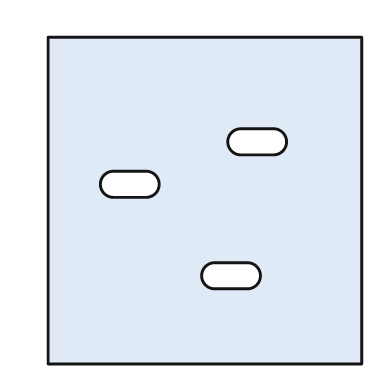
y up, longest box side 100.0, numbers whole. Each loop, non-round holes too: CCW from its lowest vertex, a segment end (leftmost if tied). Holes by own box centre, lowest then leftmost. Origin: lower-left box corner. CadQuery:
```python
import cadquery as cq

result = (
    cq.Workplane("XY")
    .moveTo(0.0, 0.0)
    .lineTo(96.0, 0.0)
    .lineTo(96.0, 100.0)
    .lineTo(0.0, 100.0)
    .close()
    .moveTo(51.0, 23.0)
    .lineTo(61.0, 23.0)
    .threePointArc((65.0, 27.0), (61.0, 31.0))
    .lineTo(51.0, 31.0)
    .threePointArc((47.0, 27.0), (51.0, 23.0))
    .close()
    .moveTo(20.0, 51.0)
    .lineTo(30.0, 51.0)
    .threePointArc((34.0, 55.0), (30.0, 59.0))
    .lineTo(20.0, 59.0)
    .threePointArc((16.0, 55.0), (20.0, 51.0))
    .close()
    .moveTo(59.0, 64.0)
    .lineTo(69.0, 64.0)
    .threePointArc((73.0, 68.0), (69.0, 72.0))
    .lineTo(59.0, 72.0)
    .threePointArc((55.0, 68.0), (59.0, 64.0))
    .close()
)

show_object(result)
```